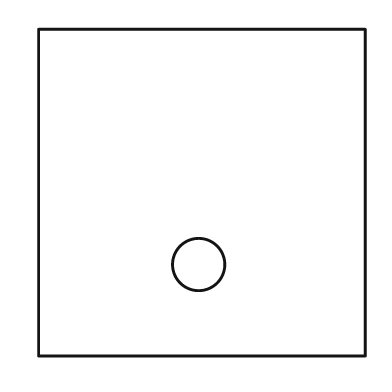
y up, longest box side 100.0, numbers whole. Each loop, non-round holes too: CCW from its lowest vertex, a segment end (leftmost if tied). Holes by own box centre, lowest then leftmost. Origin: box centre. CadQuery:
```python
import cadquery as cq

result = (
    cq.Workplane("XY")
    .moveTo(-50.0, -50.0)
    .lineTo(50.0, -50.0)
    .lineTo(50.0, 50.0)
    .lineTo(-50.0, 50.0)
    .close()
    .moveTo(-1.0, -22.0)
    .circle(8.0)
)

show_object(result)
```